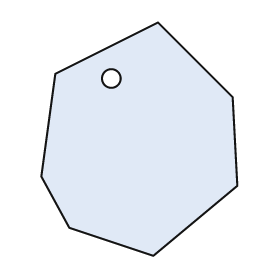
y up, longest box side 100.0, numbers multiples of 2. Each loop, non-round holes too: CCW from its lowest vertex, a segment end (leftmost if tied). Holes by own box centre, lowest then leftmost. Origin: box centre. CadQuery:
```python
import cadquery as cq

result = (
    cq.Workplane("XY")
    .moveTo(6.0, -50.0)
    .lineTo(42.0, -20.0)
    .lineTo(40.0, 18.0)
    .lineTo(8.0, 50.0)
    .lineTo(-36.0, 28.0)
    .lineTo(-42.0, -16.0)
    .lineTo(-30.0, -38.0)
    .close()
    .moveTo(-12.0, 26.0)
    .circle(4.0)
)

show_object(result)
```